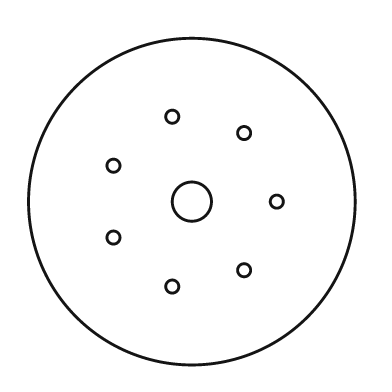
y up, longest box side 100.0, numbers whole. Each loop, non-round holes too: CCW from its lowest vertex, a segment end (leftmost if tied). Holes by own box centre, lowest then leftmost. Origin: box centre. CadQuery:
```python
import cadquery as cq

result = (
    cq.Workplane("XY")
    .moveTo(0.0, 0.0)
    .circle(50.0)
    .moveTo(-6.0, -26.0)
    .circle(2.0)
    .moveTo(16.0, -21.0)
    .circle(2.0)
    .moveTo(-24.0, -11.0)
    .circle(2.0)
    .moveTo(0.0, 0.0)
    .circle(6.0)
    .moveTo(26.0, 0.0)
    .circle(2.0)
    .moveTo(-24.0, 11.0)
    .circle(2.0)
    .moveTo(16.0, 21.0)
    .circle(2.0)
    .moveTo(-6.0, 26.0)
    .circle(2.0)
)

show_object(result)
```